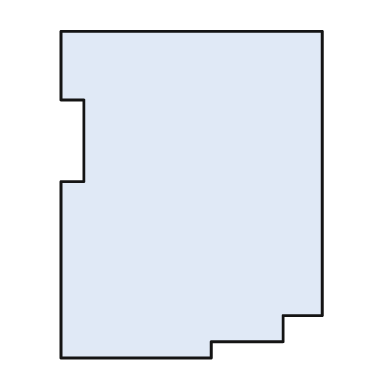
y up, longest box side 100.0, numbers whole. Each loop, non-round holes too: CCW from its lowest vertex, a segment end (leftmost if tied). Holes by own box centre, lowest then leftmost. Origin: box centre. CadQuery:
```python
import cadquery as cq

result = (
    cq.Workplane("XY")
    .moveTo(-40.0, -50.0)
    .lineTo(6.0, -50.0)
    .lineTo(6.0, -45.0)
    .lineTo(28.0, -45.0)
    .lineTo(28.0, -37.0)
    .lineTo(40.0, -37.0)
    .lineTo(40.0, 50.0)
    .lineTo(-40.0, 50.0)
    .lineTo(-40.0, 29.0)
    .lineTo(-33.0, 29.0)
    .lineTo(-33.0, 4.0)
    .lineTo(-40.0, 4.0)
    .close()
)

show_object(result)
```